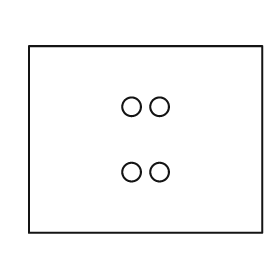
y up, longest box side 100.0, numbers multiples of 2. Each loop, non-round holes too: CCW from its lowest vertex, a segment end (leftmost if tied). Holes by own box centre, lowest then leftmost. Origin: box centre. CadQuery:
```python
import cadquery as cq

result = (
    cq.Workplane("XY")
    .moveTo(-50.0, -40.0)
    .lineTo(50.0, -40.0)
    .lineTo(50.0, 40.0)
    .lineTo(-50.0, 40.0)
    .close()
    .moveTo(-6.0, -14.0)
    .circle(4.0)
    .moveTo(6.0, -14.0)
    .circle(4.0)
    .moveTo(-6.0, 14.0)
    .circle(4.0)
    .moveTo(6.0, 14.0)
    .circle(4.0)
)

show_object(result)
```